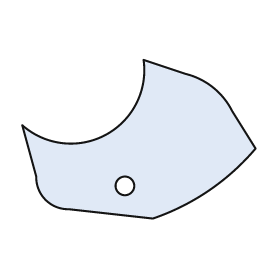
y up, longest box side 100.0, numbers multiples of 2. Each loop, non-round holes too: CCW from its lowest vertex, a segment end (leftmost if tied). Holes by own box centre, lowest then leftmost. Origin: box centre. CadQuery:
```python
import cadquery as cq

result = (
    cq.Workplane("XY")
    .moveTo(6.0, -34.0)
    .threePointArc((30.0, -22.0), (50.0, -4.0))
    .lineTo(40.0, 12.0)
    .threePointArc((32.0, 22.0), (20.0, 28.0))
    .lineTo(2.0, 34.0)
    .threePointArc((-14.0, 2.0), (-50.0, 6.0))
    .lineTo(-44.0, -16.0)
    .threePointArc((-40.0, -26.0), (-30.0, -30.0))
    .close()
    .moveTo(-6.0, -20.0)
    .circle(4.0)
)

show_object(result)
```